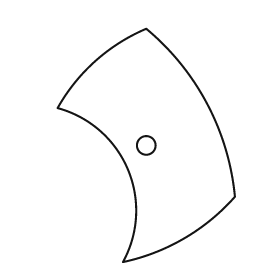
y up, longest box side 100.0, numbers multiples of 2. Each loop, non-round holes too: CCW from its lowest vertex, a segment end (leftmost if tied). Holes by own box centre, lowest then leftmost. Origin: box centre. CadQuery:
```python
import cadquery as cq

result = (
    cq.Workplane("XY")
    .moveTo(-10.0, -50.0)
    .threePointArc((16.0, -40.0), (38.0, -22.0))
    .threePointArc((26.0, 18.0), (0.0, 50.0))
    .threePointArc((-22.0, 36.0), (-38.0, 16.0))
    .threePointArc((-8.0, -10.0), (-10.0, -50.0))
    .close()
    .moveTo(0.0, 0.0)
    .circle(4.0)
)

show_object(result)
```